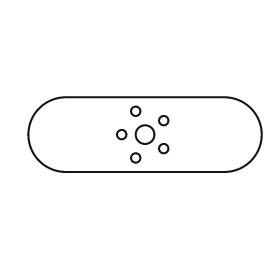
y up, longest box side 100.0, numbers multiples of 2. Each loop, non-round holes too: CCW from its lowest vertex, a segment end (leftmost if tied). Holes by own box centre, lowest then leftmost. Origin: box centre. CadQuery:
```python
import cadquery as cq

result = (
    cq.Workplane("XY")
    .moveTo(-34.0, -16.0)
    .lineTo(34.0, -16.0)
    .threePointArc((50.0, 0.0), (34.0, 16.0))
    .lineTo(-34.0, 16.0)
    .threePointArc((-50.0, 0.0), (-34.0, -16.0))
    .close()
    .moveTo(-4.0, -10.0)
    .circle(2.0)
    .moveTo(8.0, -6.0)
    .circle(2.0)
    .moveTo(-10.0, 0.0)
    .circle(2.0)
    .moveTo(0.0, 0.0)
    .circle(4.0)
    .moveTo(8.0, 6.0)
    .circle(2.0)
    .moveTo(-4.0, 10.0)
    .circle(2.0)
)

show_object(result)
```